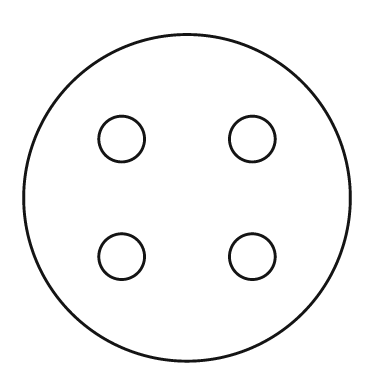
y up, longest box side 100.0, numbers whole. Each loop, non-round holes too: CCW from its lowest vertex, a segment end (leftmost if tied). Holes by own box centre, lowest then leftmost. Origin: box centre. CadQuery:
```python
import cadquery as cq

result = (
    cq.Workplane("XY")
    .moveTo(0.0, 0.0)
    .circle(50.0)
    .moveTo(-20.0, -18.0)
    .circle(7.0)
    .moveTo(20.0, -18.0)
    .circle(7.0)
    .moveTo(-20.0, 18.0)
    .circle(7.0)
    .moveTo(20.0, 18.0)
    .circle(7.0)
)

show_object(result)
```